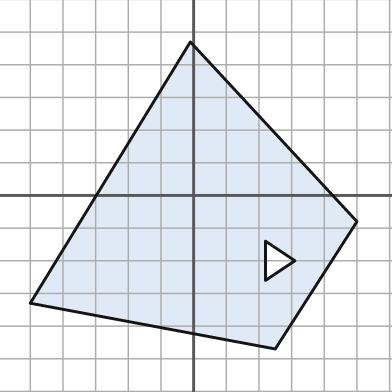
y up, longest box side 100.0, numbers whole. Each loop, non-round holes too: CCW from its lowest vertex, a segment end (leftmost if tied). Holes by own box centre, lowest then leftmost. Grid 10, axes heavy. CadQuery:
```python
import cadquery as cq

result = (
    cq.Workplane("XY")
    .moveTo(25.0, -47.0)
    .lineTo(50.0, -8.0)
    .lineTo(-1.0, 47.0)
    .lineTo(-50.0, -33.0)
    .close()
    .moveTo(22.0, -26.0)
    .lineTo(31.0, -20.0)
    .lineTo(22.0, -14.0)
    .close()
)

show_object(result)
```